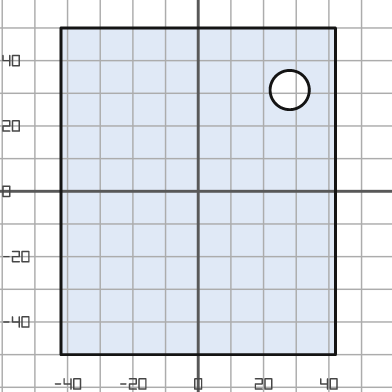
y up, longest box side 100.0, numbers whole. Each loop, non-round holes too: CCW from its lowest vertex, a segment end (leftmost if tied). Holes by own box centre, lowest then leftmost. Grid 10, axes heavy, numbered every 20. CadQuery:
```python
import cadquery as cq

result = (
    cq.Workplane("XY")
    .moveTo(-42.0, -50.0)
    .lineTo(42.0, -50.0)
    .lineTo(42.0, 50.0)
    .lineTo(-42.0, 50.0)
    .close()
    .moveTo(28.0, 31.0)
    .circle(6.0)
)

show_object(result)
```